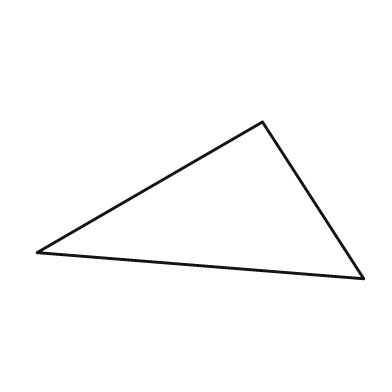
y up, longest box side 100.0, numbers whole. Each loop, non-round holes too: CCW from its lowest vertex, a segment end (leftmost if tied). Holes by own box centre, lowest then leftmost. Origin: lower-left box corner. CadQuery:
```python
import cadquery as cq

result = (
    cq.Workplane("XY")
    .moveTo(100.0, 0.0)
    .lineTo(69.0, 48.0)
    .lineTo(0.0, 8.0)
    .close()
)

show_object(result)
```